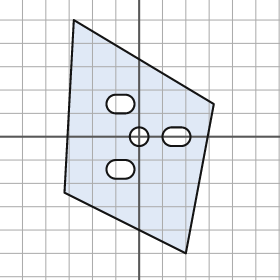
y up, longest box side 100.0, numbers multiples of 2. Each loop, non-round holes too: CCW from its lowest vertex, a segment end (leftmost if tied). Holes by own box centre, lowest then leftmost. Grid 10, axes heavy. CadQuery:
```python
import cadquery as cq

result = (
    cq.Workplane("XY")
    .moveTo(20.0, -50.0)
    .lineTo(32.0, 14.0)
    .lineTo(-28.0, 50.0)
    .lineTo(-32.0, -24.0)
    .close()
    .moveTo(-10.0, -18.0)
    .lineTo(-6.0, -18.0)
    .threePointArc((-2.0, -14.0), (-6.0, -10.0))
    .lineTo(-10.0, -10.0)
    .threePointArc((-14.0, -14.0), (-10.0, -18.0))
    .close()
    .moveTo(0.0, 0.0)
    .circle(4.0)
    .moveTo(14.0, -4.0)
    .lineTo(18.0, -4.0)
    .threePointArc((22.0, 0.0), (18.0, 4.0))
    .lineTo(14.0, 4.0)
    .threePointArc((10.0, 0.0), (14.0, -4.0))
    .close()
    .moveTo(-10.0, 10.0)
    .lineTo(-6.0, 10.0)
    .threePointArc((-2.0, 14.0), (-6.0, 18.0))
    .lineTo(-10.0, 18.0)
    .threePointArc((-14.0, 14.0), (-10.0, 10.0))
    .close()
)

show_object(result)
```